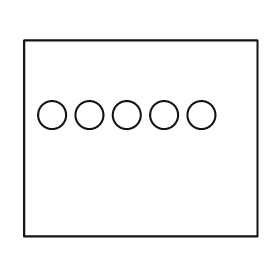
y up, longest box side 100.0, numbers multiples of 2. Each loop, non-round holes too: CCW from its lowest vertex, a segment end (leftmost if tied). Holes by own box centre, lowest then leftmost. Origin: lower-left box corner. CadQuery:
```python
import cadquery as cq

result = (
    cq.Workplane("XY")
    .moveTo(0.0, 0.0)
    .lineTo(100.0, 0.0)
    .lineTo(100.0, 84.0)
    .lineTo(0.0, 84.0)
    .close()
    .moveTo(12.0, 52.0)
    .circle(6.0)
    .moveTo(28.0, 52.0)
    .circle(6.0)
    .moveTo(44.0, 52.0)
    .circle(6.0)
    .moveTo(60.0, 52.0)
    .circle(6.0)
    .moveTo(76.0, 52.0)
    .circle(6.0)
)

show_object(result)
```